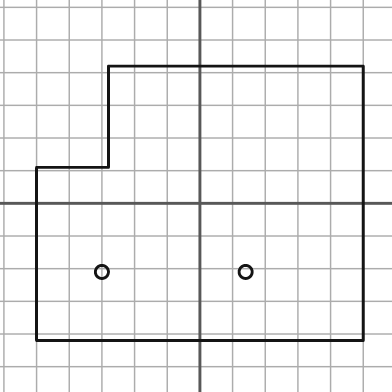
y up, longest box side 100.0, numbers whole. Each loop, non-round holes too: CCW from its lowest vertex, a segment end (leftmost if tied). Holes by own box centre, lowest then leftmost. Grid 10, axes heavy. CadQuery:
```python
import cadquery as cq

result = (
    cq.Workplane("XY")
    .moveTo(-50.0, -42.0)
    .lineTo(50.0, -42.0)
    .lineTo(50.0, 42.0)
    .lineTo(-28.0, 42.0)
    .lineTo(-28.0, 11.0)
    .lineTo(-50.0, 11.0)
    .close()
    .moveTo(-30.0, -21.0)
    .circle(2.0)
    .moveTo(14.0, -21.0)
    .circle(2.0)
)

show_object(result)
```